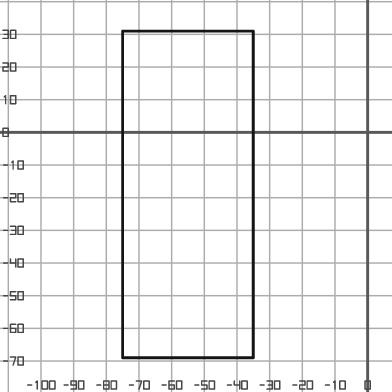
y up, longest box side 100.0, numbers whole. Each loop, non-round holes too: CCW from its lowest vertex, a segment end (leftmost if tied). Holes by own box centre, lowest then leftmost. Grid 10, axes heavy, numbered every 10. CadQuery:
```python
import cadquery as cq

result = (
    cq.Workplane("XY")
    .moveTo(-75.0, -69.0)
    .lineTo(-35.0, -69.0)
    .lineTo(-35.0, 31.0)
    .lineTo(-75.0, 31.0)
    .close()
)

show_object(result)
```